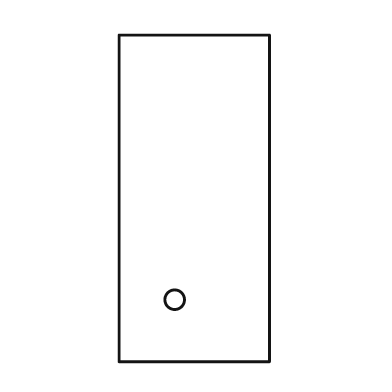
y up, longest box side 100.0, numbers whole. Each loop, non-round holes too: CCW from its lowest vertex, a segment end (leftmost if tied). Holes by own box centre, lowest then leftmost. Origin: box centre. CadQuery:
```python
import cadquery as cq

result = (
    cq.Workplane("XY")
    .moveTo(-23.0, -50.0)
    .lineTo(23.0, -50.0)
    .lineTo(23.0, 50.0)
    .lineTo(-23.0, 50.0)
    .close()
    .moveTo(-6.0, -31.0)
    .circle(3.0)
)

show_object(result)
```